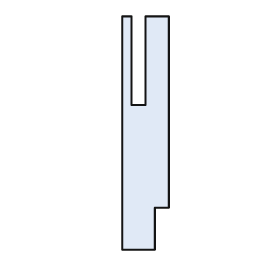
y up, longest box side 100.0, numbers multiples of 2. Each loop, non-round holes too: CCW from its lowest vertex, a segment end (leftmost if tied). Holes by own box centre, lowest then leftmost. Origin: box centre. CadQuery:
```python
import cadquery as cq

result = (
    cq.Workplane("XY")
    .moveTo(-10.0, -50.0)
    .lineTo(4.0, -50.0)
    .lineTo(4.0, -32.0)
    .lineTo(10.0, -32.0)
    .lineTo(10.0, 50.0)
    .lineTo(0.0, 50.0)
    .lineTo(0.0, 12.0)
    .lineTo(-6.0, 12.0)
    .lineTo(-6.0, 50.0)
    .lineTo(-10.0, 50.0)
    .close()
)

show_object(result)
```